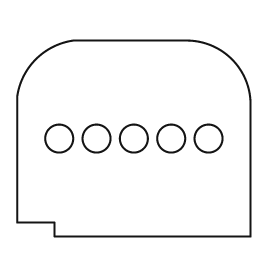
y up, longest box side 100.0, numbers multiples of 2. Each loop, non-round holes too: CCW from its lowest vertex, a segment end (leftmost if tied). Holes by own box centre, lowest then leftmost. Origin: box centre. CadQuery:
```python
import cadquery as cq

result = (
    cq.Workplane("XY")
    .moveTo(-34.0, -42.0)
    .lineTo(50.0, -42.0)
    .lineTo(50.0, 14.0)
    .threePointArc((42.0, 34.0), (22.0, 42.0))
    .lineTo(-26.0, 42.0)
    .threePointArc((-42.0, 34.0), (-50.0, 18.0))
    .lineTo(-50.0, -36.0)
    .lineTo(-34.0, -36.0)
    .close()
    .moveTo(-32.0, 0.0)
    .circle(6.0)
    .moveTo(-16.0, 0.0)
    .circle(6.0)
    .moveTo(0.0, 0.0)
    .circle(6.0)
    .moveTo(16.0, 0.0)
    .circle(6.0)
    .moveTo(32.0, 0.0)
    .circle(6.0)
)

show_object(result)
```